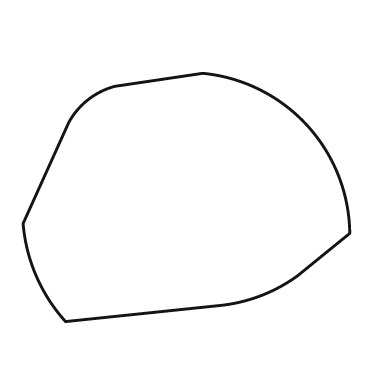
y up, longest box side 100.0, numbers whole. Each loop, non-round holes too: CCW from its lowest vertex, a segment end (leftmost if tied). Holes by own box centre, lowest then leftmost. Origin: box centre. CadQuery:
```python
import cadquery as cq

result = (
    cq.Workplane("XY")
    .moveTo(-37.0, -38.0)
    .lineTo(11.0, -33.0)
    .threePointArc((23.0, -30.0), (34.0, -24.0))
    .lineTo(50.0, -11.0)
    .threePointArc((37.0, 22.0), (5.0, 38.0))
    .lineTo(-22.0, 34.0)
    .threePointArc((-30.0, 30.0), (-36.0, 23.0))
    .lineTo(-50.0, -8.0)
    .threePointArc((-46.0, -24.0), (-37.0, -38.0))
    .close()
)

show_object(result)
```